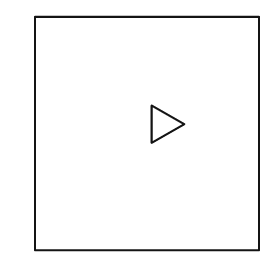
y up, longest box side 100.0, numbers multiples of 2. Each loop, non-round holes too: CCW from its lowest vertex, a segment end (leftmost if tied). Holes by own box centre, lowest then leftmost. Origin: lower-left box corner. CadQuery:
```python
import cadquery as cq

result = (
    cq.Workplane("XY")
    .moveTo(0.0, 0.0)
    .lineTo(96.0, 0.0)
    .lineTo(96.0, 100.0)
    .lineTo(0.0, 100.0)
    .close()
    .moveTo(50.0, 46.0)
    .lineTo(64.0, 54.0)
    .lineTo(50.0, 62.0)
    .close()
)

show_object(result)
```